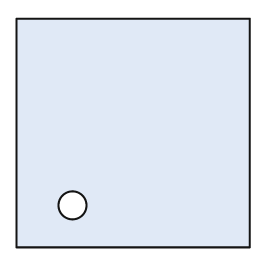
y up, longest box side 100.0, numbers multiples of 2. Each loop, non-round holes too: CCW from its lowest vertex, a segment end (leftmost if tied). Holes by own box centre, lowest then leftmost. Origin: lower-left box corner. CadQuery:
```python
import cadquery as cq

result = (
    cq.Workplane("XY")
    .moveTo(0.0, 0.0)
    .lineTo(100.0, 0.0)
    .lineTo(100.0, 98.0)
    .lineTo(0.0, 98.0)
    .close()
    .moveTo(24.0, 18.0)
    .circle(6.0)
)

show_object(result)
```